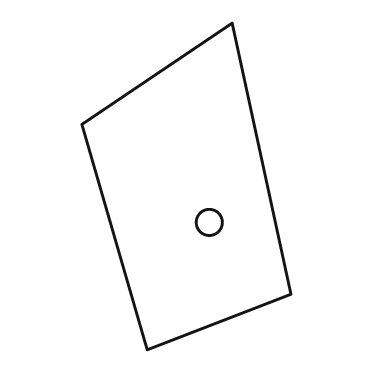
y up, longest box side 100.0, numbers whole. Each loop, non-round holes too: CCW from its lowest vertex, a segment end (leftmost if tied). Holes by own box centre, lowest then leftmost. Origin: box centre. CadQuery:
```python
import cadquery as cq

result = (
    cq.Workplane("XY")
    .moveTo(-12.0, -50.0)
    .lineTo(32.0, -33.0)
    .lineTo(14.0, 50.0)
    .lineTo(-32.0, 19.0)
    .close()
    .moveTo(7.0, -11.0)
    .circle(4.0)
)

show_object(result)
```